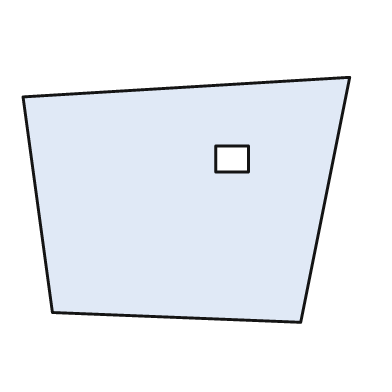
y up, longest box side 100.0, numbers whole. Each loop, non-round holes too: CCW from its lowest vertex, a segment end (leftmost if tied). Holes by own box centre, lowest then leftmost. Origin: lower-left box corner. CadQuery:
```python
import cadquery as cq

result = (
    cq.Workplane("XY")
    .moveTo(85.0, 0.0)
    .lineTo(100.0, 75.0)
    .lineTo(0.0, 69.0)
    .lineTo(9.0, 3.0)
    .close()
    .moveTo(59.0, 46.0)
    .lineTo(69.0, 46.0)
    .lineTo(69.0, 54.0)
    .lineTo(59.0, 54.0)
    .close()
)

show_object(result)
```